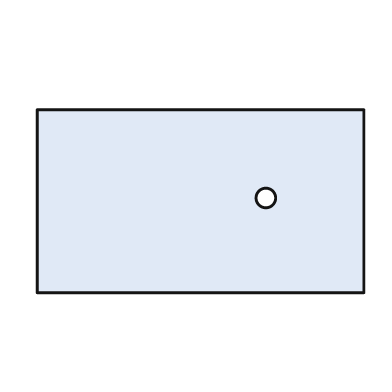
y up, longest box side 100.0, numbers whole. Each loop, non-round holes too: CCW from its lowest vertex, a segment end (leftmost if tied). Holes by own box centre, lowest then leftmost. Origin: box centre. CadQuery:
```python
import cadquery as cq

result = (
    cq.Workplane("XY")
    .moveTo(-50.0, -28.0)
    .lineTo(50.0, -28.0)
    .lineTo(50.0, 28.0)
    .lineTo(-50.0, 28.0)
    .close()
    .moveTo(20.0, 1.0)
    .circle(3.0)
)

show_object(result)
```